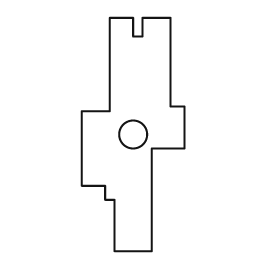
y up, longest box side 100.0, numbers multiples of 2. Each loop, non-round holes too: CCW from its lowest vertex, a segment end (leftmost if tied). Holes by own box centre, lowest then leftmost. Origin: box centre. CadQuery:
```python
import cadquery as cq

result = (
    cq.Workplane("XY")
    .moveTo(-8.0, -50.0)
    .lineTo(8.0, -50.0)
    .lineTo(8.0, -6.0)
    .lineTo(22.0, -6.0)
    .lineTo(22.0, 12.0)
    .lineTo(16.0, 12.0)
    .lineTo(16.0, 50.0)
    .lineTo(4.0, 50.0)
    .lineTo(4.0, 42.0)
    .lineTo(0.0, 42.0)
    .lineTo(0.0, 50.0)
    .lineTo(-10.0, 50.0)
    .lineTo(-10.0, 10.0)
    .lineTo(-22.0, 10.0)
    .lineTo(-22.0, -22.0)
    .lineTo(-12.0, -22.0)
    .lineTo(-12.0, -28.0)
    .lineTo(-8.0, -28.0)
    .close()
    .moveTo(0.0, 0.0)
    .circle(6.0)
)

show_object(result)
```